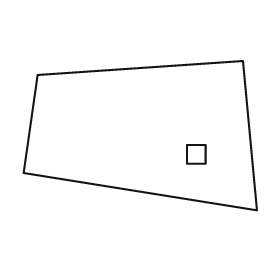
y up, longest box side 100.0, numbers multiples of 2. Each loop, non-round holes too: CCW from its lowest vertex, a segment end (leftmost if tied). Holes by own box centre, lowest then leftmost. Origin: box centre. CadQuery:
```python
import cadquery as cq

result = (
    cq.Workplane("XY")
    .moveTo(50.0, -32.0)
    .lineTo(44.0, 32.0)
    .lineTo(-44.0, 26.0)
    .lineTo(-50.0, -16.0)
    .close()
    .moveTo(20.0, -12.0)
    .lineTo(28.0, -12.0)
    .lineTo(28.0, -4.0)
    .lineTo(20.0, -4.0)
    .close()
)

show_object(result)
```